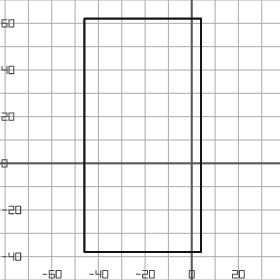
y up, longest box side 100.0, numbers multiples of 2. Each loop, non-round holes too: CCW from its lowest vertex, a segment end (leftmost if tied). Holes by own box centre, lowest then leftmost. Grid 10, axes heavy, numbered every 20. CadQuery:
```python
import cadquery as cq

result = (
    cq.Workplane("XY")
    .moveTo(-46.0, -38.0)
    .lineTo(4.0, -38.0)
    .lineTo(4.0, 62.0)
    .lineTo(-46.0, 62.0)
    .close()
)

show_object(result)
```